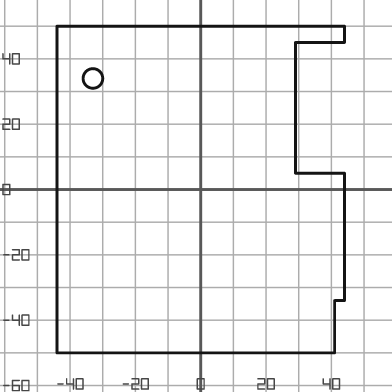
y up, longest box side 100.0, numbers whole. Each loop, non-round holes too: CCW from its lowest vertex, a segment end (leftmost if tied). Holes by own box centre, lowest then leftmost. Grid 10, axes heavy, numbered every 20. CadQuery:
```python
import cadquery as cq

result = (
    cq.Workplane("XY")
    .moveTo(-44.0, -50.0)
    .lineTo(41.0, -50.0)
    .lineTo(41.0, -34.0)
    .lineTo(44.0, -34.0)
    .lineTo(44.0, 5.0)
    .lineTo(29.0, 5.0)
    .lineTo(29.0, 45.0)
    .lineTo(44.0, 45.0)
    .lineTo(44.0, 50.0)
    .lineTo(-44.0, 50.0)
    .close()
    .moveTo(-33.0, 34.0)
    .circle(3.0)
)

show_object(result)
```